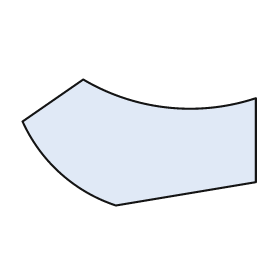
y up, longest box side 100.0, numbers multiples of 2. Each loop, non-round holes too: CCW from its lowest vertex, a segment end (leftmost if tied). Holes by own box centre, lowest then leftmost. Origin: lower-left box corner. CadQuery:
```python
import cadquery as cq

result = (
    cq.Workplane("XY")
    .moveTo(40.0, 0.0)
    .lineTo(100.0, 10.0)
    .lineTo(100.0, 46.0)
    .threePointArc((62.0, 42.0), (26.0, 54.0))
    .lineTo(0.0, 36.0)
    .threePointArc((16.0, 14.0), (40.0, 0.0))
    .close()
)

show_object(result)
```